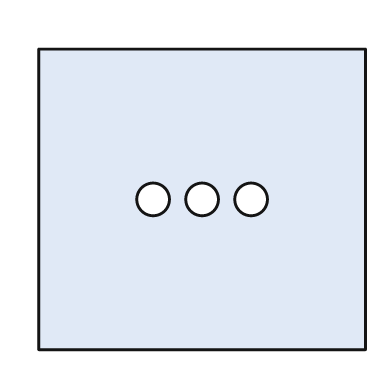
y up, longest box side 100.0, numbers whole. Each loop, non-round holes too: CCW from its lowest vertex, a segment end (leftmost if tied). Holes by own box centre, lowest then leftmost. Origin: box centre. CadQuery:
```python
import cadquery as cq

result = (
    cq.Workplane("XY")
    .moveTo(-50.0, -46.0)
    .lineTo(50.0, -46.0)
    .lineTo(50.0, 46.0)
    .lineTo(-50.0, 46.0)
    .close()
    .moveTo(-15.0, 0.0)
    .circle(5.0)
    .moveTo(0.0, 0.0)
    .circle(5.0)
    .moveTo(15.0, 0.0)
    .circle(5.0)
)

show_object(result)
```